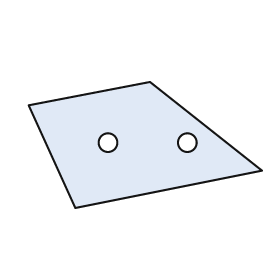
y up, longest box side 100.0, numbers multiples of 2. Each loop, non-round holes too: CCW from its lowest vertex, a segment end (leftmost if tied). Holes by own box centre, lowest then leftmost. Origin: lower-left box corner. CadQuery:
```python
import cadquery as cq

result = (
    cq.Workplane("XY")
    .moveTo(20.0, 0.0)
    .lineTo(100.0, 16.0)
    .lineTo(52.0, 54.0)
    .lineTo(0.0, 44.0)
    .close()
    .moveTo(34.0, 28.0)
    .circle(4.0)
    .moveTo(68.0, 28.0)
    .circle(4.0)
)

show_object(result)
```